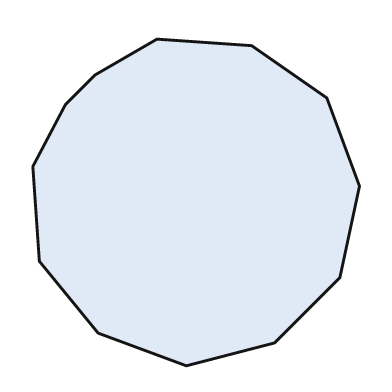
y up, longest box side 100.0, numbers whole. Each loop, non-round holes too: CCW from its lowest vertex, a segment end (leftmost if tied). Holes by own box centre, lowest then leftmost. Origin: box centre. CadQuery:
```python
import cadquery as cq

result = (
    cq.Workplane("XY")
    .moveTo(-3.0, -50.0)
    .lineTo(24.0, -43.0)
    .lineTo(44.0, -23.0)
    .lineTo(50.0, 5.0)
    .lineTo(40.0, 32.0)
    .lineTo(17.0, 48.0)
    .lineTo(-12.0, 50.0)
    .lineTo(-31.0, 39.0)
    .lineTo(-40.0, 30.0)
    .lineTo(-50.0, 11.0)
    .lineTo(-48.0, -18.0)
    .lineTo(-30.0, -40.0)
    .close()
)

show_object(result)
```